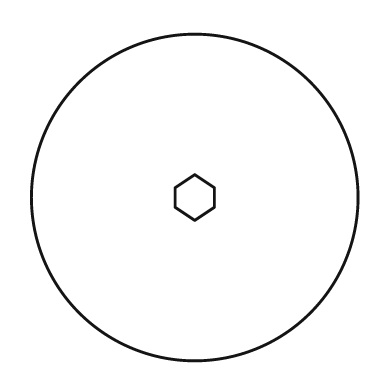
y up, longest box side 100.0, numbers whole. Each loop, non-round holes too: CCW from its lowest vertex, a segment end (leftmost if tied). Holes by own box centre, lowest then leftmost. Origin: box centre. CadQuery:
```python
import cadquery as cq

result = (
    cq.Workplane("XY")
    .moveTo(0.0, 0.0)
    .circle(50.0)
    .moveTo(0.0, -7.0)
    .lineTo(6.0, -3.0)
    .lineTo(6.0, 3.0)
    .lineTo(0.0, 7.0)
    .lineTo(-6.0, 3.0)
    .lineTo(-6.0, -3.0)
    .close()
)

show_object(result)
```